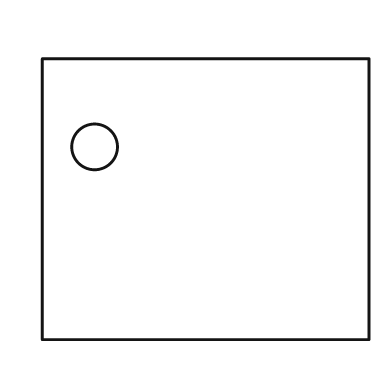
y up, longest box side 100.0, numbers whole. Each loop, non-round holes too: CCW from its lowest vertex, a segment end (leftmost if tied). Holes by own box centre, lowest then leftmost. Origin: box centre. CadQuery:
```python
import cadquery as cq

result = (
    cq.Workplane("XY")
    .moveTo(-50.0, -43.0)
    .lineTo(50.0, -43.0)
    .lineTo(50.0, 43.0)
    .lineTo(-50.0, 43.0)
    .close()
    .moveTo(-34.0, 16.0)
    .circle(7.0)
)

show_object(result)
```